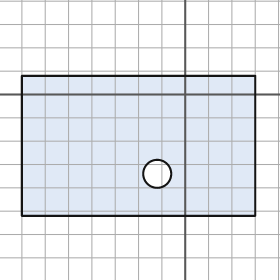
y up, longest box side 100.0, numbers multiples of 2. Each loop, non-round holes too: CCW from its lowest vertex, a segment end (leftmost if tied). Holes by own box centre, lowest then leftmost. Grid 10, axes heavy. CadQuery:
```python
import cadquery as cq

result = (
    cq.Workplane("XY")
    .moveTo(-70.0, -52.0)
    .lineTo(30.0, -52.0)
    .lineTo(30.0, 8.0)
    .lineTo(-70.0, 8.0)
    .close()
    .moveTo(-12.0, -34.0)
    .circle(6.0)
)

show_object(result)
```